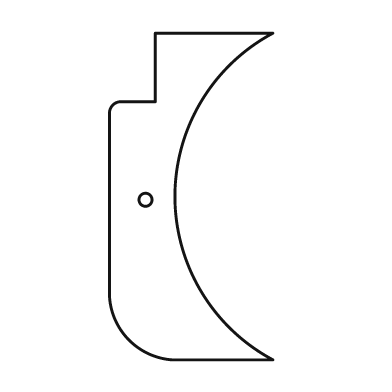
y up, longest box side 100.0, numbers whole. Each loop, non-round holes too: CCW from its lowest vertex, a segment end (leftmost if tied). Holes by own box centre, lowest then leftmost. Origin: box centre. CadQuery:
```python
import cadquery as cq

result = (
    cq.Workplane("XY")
    .moveTo(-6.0, -50.0)
    .lineTo(25.0, -50.0)
    .threePointArc((-5.0, 0.0), (25.0, 50.0))
    .lineTo(-11.0, 50.0)
    .lineTo(-11.0, 29.0)
    .lineTo(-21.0, 29.0)
    .threePointArc((-24.0, 28.0), (-25.0, 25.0))
    .lineTo(-25.0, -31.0)
    .threePointArc((-19.0, -44.0), (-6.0, -50.0))
    .close()
    .moveTo(-14.0, -1.0)
    .circle(2.0)
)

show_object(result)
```